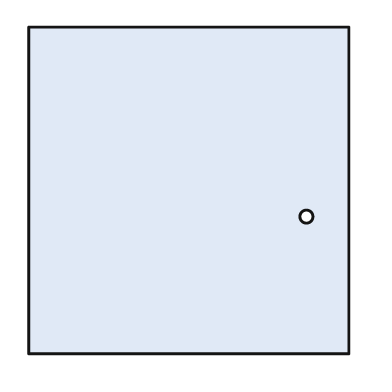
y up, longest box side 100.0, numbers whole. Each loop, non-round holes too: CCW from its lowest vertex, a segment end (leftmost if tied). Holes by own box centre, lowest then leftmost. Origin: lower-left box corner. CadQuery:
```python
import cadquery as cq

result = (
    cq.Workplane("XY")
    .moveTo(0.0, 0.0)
    .lineTo(98.0, 0.0)
    .lineTo(98.0, 100.0)
    .lineTo(0.0, 100.0)
    .close()
    .moveTo(85.0, 42.0)
    .circle(2.0)
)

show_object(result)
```